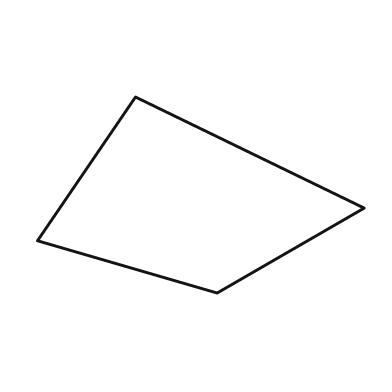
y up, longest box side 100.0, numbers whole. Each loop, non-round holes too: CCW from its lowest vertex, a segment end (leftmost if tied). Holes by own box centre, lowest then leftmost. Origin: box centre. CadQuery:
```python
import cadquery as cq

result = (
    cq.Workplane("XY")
    .moveTo(5.0, -30.0)
    .lineTo(50.0, -4.0)
    .lineTo(-20.0, 30.0)
    .lineTo(-50.0, -14.0)
    .close()
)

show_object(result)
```